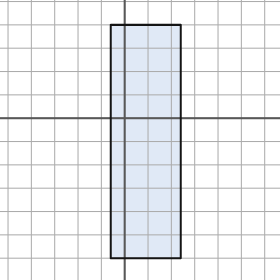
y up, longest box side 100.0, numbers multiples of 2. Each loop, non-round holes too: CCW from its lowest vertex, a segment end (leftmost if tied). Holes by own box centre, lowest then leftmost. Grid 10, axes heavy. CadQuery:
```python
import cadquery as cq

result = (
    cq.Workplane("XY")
    .moveTo(-6.0, -60.0)
    .lineTo(24.0, -60.0)
    .lineTo(24.0, 40.0)
    .lineTo(-6.0, 40.0)
    .close()
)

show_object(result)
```